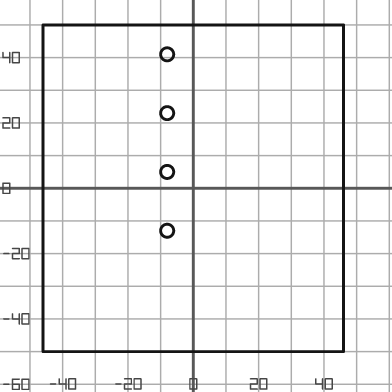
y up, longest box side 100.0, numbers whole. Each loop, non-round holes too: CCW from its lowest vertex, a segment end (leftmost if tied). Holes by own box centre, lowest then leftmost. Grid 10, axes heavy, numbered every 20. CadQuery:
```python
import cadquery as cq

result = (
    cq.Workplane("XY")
    .moveTo(-46.0, -50.0)
    .lineTo(46.0, -50.0)
    .lineTo(46.0, 50.0)
    .lineTo(-46.0, 50.0)
    .close()
    .moveTo(-8.0, -13.0)
    .circle(2.0)
    .moveTo(-8.0, 5.0)
    .circle(2.0)
    .moveTo(-8.0, 23.0)
    .circle(2.0)
    .moveTo(-8.0, 41.0)
    .circle(2.0)
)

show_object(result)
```